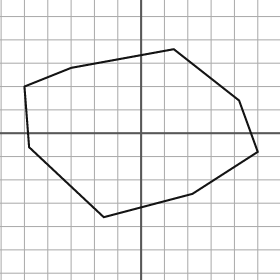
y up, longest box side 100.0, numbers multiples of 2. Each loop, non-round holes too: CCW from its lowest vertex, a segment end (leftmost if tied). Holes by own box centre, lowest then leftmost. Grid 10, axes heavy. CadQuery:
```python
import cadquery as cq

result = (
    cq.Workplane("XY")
    .moveTo(-16.0, -36.0)
    .lineTo(22.0, -26.0)
    .lineTo(50.0, -8.0)
    .lineTo(42.0, 14.0)
    .lineTo(14.0, 36.0)
    .lineTo(-30.0, 28.0)
    .lineTo(-50.0, 20.0)
    .lineTo(-48.0, -6.0)
    .close()
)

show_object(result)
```